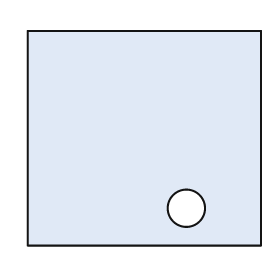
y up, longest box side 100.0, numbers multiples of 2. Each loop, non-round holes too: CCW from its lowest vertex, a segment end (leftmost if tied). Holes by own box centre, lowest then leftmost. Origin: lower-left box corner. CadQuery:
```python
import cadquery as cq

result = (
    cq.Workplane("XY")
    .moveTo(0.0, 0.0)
    .lineTo(100.0, 0.0)
    .lineTo(100.0, 92.0)
    .lineTo(0.0, 92.0)
    .close()
    .moveTo(68.0, 16.0)
    .circle(8.0)
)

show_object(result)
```